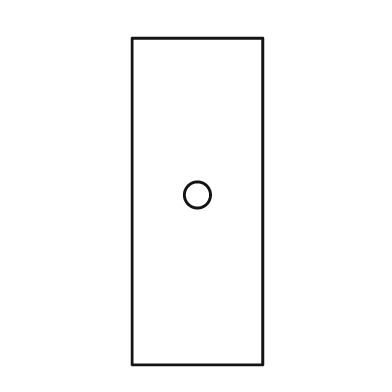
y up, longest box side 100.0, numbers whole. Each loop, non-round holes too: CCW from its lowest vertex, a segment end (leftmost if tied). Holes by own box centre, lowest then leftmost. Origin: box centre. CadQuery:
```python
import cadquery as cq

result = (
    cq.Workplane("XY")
    .moveTo(-20.0, -50.0)
    .lineTo(20.0, -50.0)
    .lineTo(20.0, 50.0)
    .lineTo(-20.0, 50.0)
    .close()
    .moveTo(0.0, 2.0)
    .circle(4.0)
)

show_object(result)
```